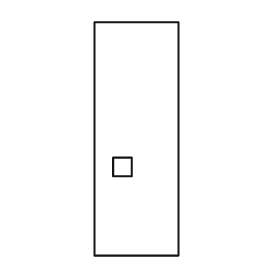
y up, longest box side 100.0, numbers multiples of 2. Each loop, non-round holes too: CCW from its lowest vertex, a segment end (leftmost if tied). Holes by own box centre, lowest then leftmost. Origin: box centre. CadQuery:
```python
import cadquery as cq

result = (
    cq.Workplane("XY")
    .moveTo(-18.0, -50.0)
    .lineTo(18.0, -50.0)
    .lineTo(18.0, 50.0)
    .lineTo(-18.0, 50.0)
    .close()
    .moveTo(-10.0, -16.0)
    .lineTo(-2.0, -16.0)
    .lineTo(-2.0, -8.0)
    .lineTo(-10.0, -8.0)
    .close()
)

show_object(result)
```